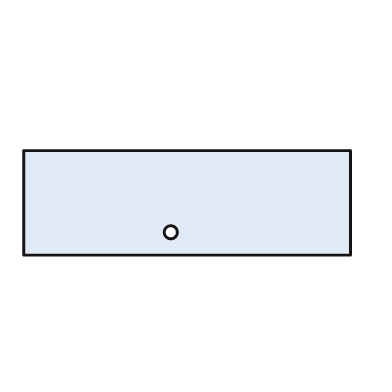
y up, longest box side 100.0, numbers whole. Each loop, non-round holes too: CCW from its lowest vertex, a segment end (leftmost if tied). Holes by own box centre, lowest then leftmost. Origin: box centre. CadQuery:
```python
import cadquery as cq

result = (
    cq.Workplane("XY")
    .moveTo(-50.0, -16.0)
    .lineTo(50.0, -16.0)
    .lineTo(50.0, 16.0)
    .lineTo(-50.0, 16.0)
    .close()
    .moveTo(-5.0, -9.0)
    .circle(2.0)
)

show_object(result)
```